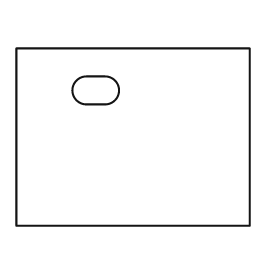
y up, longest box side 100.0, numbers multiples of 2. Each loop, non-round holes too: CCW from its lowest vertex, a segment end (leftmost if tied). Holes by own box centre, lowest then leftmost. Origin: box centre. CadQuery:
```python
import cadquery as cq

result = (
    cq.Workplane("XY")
    .moveTo(-50.0, -38.0)
    .lineTo(50.0, -38.0)
    .lineTo(50.0, 38.0)
    .lineTo(-50.0, 38.0)
    .close()
    .moveTo(-20.0, 14.0)
    .lineTo(-12.0, 14.0)
    .threePointArc((-6.0, 20.0), (-12.0, 26.0))
    .lineTo(-20.0, 26.0)
    .threePointArc((-26.0, 20.0), (-20.0, 14.0))
    .close()
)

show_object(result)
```